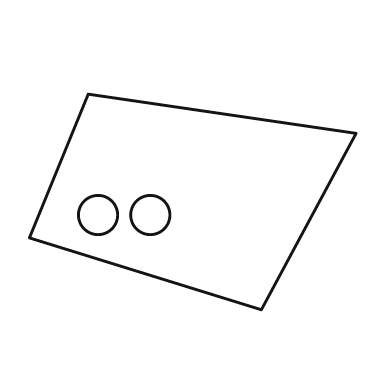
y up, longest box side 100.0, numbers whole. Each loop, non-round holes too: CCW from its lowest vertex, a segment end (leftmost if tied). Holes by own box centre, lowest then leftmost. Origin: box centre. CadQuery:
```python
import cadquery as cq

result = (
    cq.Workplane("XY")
    .moveTo(21.0, -33.0)
    .lineTo(50.0, 21.0)
    .lineTo(-32.0, 33.0)
    .lineTo(-50.0, -11.0)
    .close()
    .moveTo(-29.0, -4.0)
    .circle(6.0)
    .moveTo(-13.0, -4.0)
    .circle(6.0)
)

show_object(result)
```